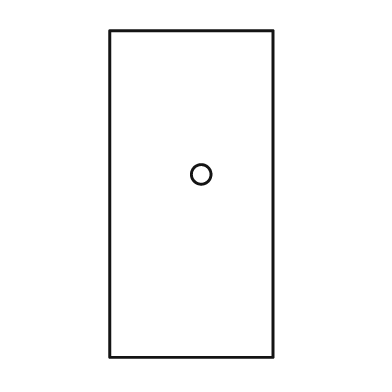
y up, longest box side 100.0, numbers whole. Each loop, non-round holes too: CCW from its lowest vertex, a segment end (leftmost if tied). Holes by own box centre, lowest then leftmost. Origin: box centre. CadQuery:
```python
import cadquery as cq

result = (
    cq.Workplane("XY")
    .moveTo(-25.0, -50.0)
    .lineTo(25.0, -50.0)
    .lineTo(25.0, 50.0)
    .lineTo(-25.0, 50.0)
    .close()
    .moveTo(3.0, 6.0)
    .circle(3.0)
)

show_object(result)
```